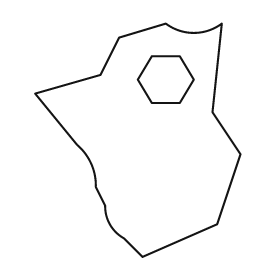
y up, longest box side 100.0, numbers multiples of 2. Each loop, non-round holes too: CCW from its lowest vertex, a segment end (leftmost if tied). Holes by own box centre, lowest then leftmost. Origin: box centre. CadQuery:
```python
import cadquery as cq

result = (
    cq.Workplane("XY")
    .moveTo(2.0, -50.0)
    .lineTo(34.0, -36.0)
    .lineTo(44.0, -6.0)
    .lineTo(32.0, 12.0)
    .lineTo(36.0, 50.0)
    .threePointArc((24.0, 46.0), (12.0, 50.0))
    .lineTo(-8.0, 44.0)
    .lineTo(-16.0, 28.0)
    .lineTo(-44.0, 20.0)
    .lineTo(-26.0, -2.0)
    .threePointArc((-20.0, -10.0), (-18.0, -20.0))
    .lineTo(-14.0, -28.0)
    .threePointArc((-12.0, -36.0), (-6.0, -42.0))
    .close()
    .moveTo(6.0, 16.0)
    .lineTo(18.0, 16.0)
    .lineTo(24.0, 26.0)
    .lineTo(18.0, 36.0)
    .lineTo(6.0, 36.0)
    .lineTo(0.0, 26.0)
    .close()
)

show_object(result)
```